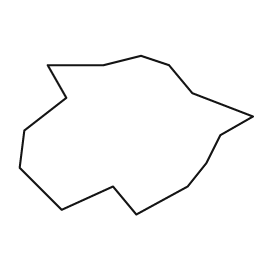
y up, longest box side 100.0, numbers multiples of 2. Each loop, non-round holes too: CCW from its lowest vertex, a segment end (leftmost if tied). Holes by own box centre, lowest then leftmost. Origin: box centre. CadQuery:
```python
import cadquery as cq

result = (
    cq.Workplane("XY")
    .moveTo(0.0, -34.0)
    .lineTo(22.0, -22.0)
    .lineTo(30.0, -12.0)
    .lineTo(36.0, 0.0)
    .lineTo(50.0, 8.0)
    .lineTo(24.0, 18.0)
    .lineTo(14.0, 30.0)
    .lineTo(2.0, 34.0)
    .lineTo(-14.0, 30.0)
    .lineTo(-38.0, 30.0)
    .lineTo(-30.0, 16.0)
    .lineTo(-48.0, 2.0)
    .lineTo(-50.0, -14.0)
    .lineTo(-32.0, -32.0)
    .lineTo(-10.0, -22.0)
    .close()
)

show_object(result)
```